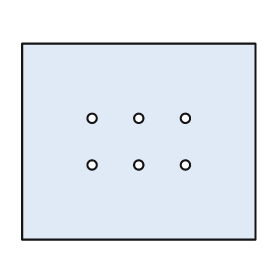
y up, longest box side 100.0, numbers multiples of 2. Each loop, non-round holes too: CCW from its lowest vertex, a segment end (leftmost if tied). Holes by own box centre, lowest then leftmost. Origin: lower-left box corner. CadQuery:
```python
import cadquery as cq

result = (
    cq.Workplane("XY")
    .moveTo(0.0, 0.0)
    .lineTo(100.0, 0.0)
    .lineTo(100.0, 84.0)
    .lineTo(0.0, 84.0)
    .close()
    .moveTo(30.0, 32.0)
    .circle(2.0)
    .moveTo(50.0, 32.0)
    .circle(2.0)
    .moveTo(70.0, 32.0)
    .circle(2.0)
    .moveTo(30.0, 52.0)
    .circle(2.0)
    .moveTo(50.0, 52.0)
    .circle(2.0)
    .moveTo(70.0, 52.0)
    .circle(2.0)
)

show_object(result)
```